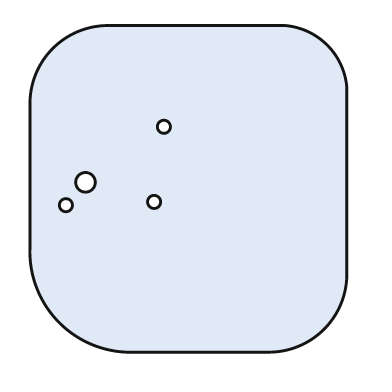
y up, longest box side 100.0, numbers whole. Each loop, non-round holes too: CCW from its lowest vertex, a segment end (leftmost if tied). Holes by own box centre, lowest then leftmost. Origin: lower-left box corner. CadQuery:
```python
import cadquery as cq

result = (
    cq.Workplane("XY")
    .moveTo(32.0, 0.0)
    .lineTo(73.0, 0.0)
    .threePointArc((90.0, 7.0), (97.0, 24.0))
    .lineTo(97.0, 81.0)
    .threePointArc((91.0, 94.0), (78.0, 100.0))
    .lineTo(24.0, 100.0)
    .threePointArc((7.0, 93.0), (0.0, 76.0))
    .lineTo(0.0, 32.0)
    .threePointArc((9.0, 9.0), (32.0, 0.0))
    .close()
    .moveTo(11.0, 45.0)
    .circle(2.0)
    .moveTo(38.0, 46.0)
    .circle(2.0)
    .moveTo(17.0, 52.0)
    .circle(3.0)
    .moveTo(41.0, 69.0)
    .circle(2.0)
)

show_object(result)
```